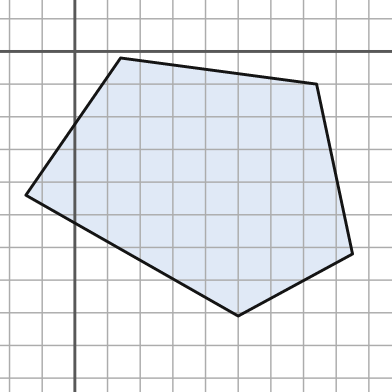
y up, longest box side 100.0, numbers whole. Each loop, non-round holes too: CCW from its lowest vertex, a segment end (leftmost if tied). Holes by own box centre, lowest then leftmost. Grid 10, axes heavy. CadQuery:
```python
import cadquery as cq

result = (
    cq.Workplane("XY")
    .moveTo(50.0, -81.0)
    .lineTo(85.0, -62.0)
    .lineTo(74.0, -10.0)
    .lineTo(14.0, -2.0)
    .lineTo(-15.0, -44.0)
    .close()
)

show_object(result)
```